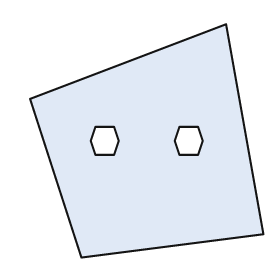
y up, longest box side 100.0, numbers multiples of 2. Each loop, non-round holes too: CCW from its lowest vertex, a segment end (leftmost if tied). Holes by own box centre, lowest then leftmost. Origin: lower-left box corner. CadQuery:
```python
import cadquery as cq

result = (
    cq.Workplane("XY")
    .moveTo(22.0, 0.0)
    .lineTo(100.0, 10.0)
    .lineTo(84.0, 100.0)
    .lineTo(0.0, 68.0)
    .close()
    .moveTo(28.0, 44.0)
    .lineTo(36.0, 44.0)
    .lineTo(38.0, 50.0)
    .lineTo(36.0, 56.0)
    .lineTo(28.0, 56.0)
    .lineTo(26.0, 50.0)
    .close()
    .moveTo(64.0, 44.0)
    .lineTo(72.0, 44.0)
    .lineTo(74.0, 50.0)
    .lineTo(72.0, 56.0)
    .lineTo(64.0, 56.0)
    .lineTo(62.0, 50.0)
    .close()
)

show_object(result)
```